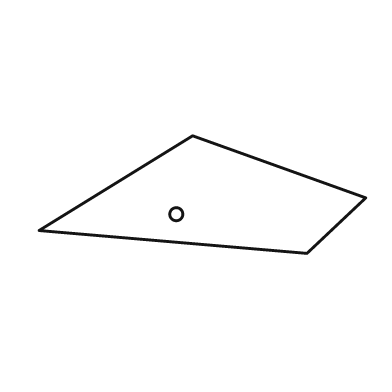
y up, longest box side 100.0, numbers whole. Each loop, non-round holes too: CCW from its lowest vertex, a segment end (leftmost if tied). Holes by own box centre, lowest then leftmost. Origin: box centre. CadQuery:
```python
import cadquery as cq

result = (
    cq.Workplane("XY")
    .moveTo(32.0, -18.0)
    .lineTo(50.0, -1.0)
    .lineTo(-3.0, 18.0)
    .lineTo(-50.0, -11.0)
    .close()
    .moveTo(-8.0, -6.0)
    .circle(2.0)
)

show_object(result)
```